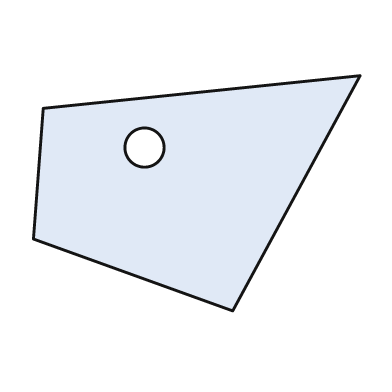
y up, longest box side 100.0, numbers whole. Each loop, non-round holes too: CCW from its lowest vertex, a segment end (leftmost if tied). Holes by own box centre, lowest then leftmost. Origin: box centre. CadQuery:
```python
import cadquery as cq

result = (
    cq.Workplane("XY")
    .moveTo(11.0, -36.0)
    .lineTo(50.0, 36.0)
    .lineTo(-47.0, 26.0)
    .lineTo(-50.0, -14.0)
    .close()
    .moveTo(-16.0, 14.0)
    .circle(6.0)
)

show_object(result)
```